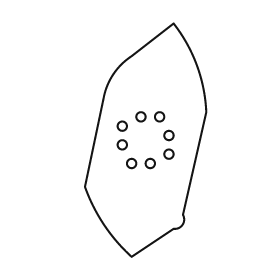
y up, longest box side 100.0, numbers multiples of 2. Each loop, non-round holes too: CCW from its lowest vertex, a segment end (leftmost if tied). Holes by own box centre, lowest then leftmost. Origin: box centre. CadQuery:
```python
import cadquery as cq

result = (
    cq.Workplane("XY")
    .moveTo(-6.0, -50.0)
    .lineTo(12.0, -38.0)
    .threePointArc((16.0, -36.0), (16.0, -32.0))
    .lineTo(26.0, 12.0)
    .threePointArc((22.0, 32.0), (12.0, 50.0))
    .lineTo(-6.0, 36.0)
    .threePointArc((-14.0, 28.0), (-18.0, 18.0))
    .lineTo(-26.0, -20.0)
    .threePointArc((-18.0, -36.0), (-6.0, -50.0))
    .close()
    .moveTo(-6.0, -10.0)
    .circle(2.0)
    .moveTo(2.0, -10.0)
    .circle(2.0)
    .moveTo(10.0, -6.0)
    .circle(2.0)
    .moveTo(-10.0, -2.0)
    .circle(2.0)
    .moveTo(10.0, 2.0)
    .circle(2.0)
    .moveTo(-10.0, 6.0)
    .circle(2.0)
    .moveTo(-2.0, 10.0)
    .circle(2.0)
    .moveTo(6.0, 10.0)
    .circle(2.0)
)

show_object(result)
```